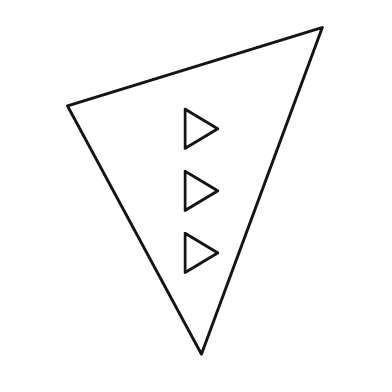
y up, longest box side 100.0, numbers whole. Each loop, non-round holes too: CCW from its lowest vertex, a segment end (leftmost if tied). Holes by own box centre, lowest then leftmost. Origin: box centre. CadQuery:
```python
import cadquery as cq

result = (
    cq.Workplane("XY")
    .moveTo(2.0, -50.0)
    .lineTo(39.0, 50.0)
    .lineTo(-39.0, 26.0)
    .close()
    .moveTo(-3.0, -25.0)
    .lineTo(7.0, -19.0)
    .lineTo(-3.0, -13.0)
    .close()
    .moveTo(-3.0, -6.0)
    .lineTo(7.0, 0.0)
    .lineTo(-3.0, 6.0)
    .close()
    .moveTo(-3.0, 13.0)
    .lineTo(7.0, 19.0)
    .lineTo(-3.0, 25.0)
    .close()
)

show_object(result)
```